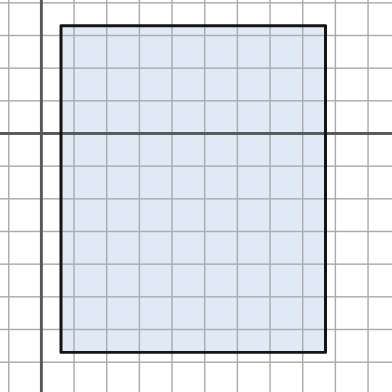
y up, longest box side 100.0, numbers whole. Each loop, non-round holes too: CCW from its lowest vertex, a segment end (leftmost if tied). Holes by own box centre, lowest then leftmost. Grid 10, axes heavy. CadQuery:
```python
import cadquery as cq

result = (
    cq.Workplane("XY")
    .moveTo(6.0, -67.0)
    .lineTo(87.0, -67.0)
    .lineTo(87.0, 33.0)
    .lineTo(6.0, 33.0)
    .close()
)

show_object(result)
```